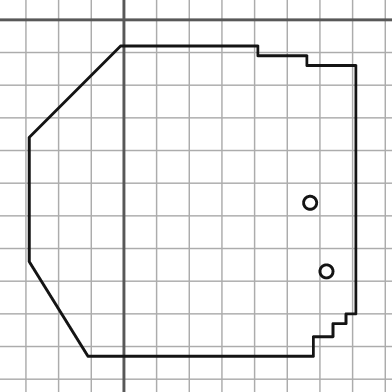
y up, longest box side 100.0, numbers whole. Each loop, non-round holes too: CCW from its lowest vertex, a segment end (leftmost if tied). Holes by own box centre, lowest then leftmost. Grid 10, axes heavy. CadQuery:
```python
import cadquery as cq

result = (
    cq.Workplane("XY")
    .moveTo(-11.0, -103.0)
    .lineTo(58.0, -103.0)
    .lineTo(58.0, -97.0)
    .lineTo(64.0, -97.0)
    .lineTo(64.0, -93.0)
    .lineTo(68.0, -93.0)
    .lineTo(68.0, -90.0)
    .lineTo(71.0, -90.0)
    .lineTo(71.0, -14.0)
    .lineTo(56.0, -14.0)
    .lineTo(56.0, -11.0)
    .lineTo(41.0, -11.0)
    .lineTo(41.0, -8.0)
    .lineTo(-1.0, -8.0)
    .lineTo(-29.0, -36.0)
    .lineTo(-29.0, -74.0)
    .close()
    .moveTo(62.0, -77.0)
    .circle(2.0)
    .moveTo(57.0, -56.0)
    .circle(2.0)
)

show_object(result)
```